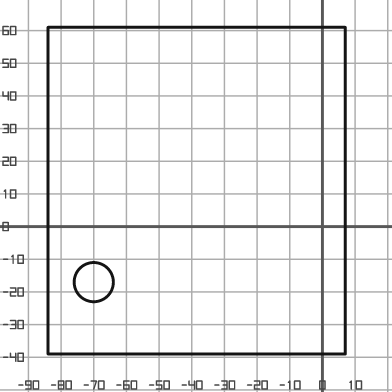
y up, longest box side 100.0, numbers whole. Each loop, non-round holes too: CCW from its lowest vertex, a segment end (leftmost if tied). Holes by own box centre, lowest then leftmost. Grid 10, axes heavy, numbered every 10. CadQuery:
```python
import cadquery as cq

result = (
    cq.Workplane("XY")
    .moveTo(-84.0, -39.0)
    .lineTo(7.0, -39.0)
    .lineTo(7.0, 61.0)
    .lineTo(-84.0, 61.0)
    .close()
    .moveTo(-70.0, -17.0)
    .circle(6.0)
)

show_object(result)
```